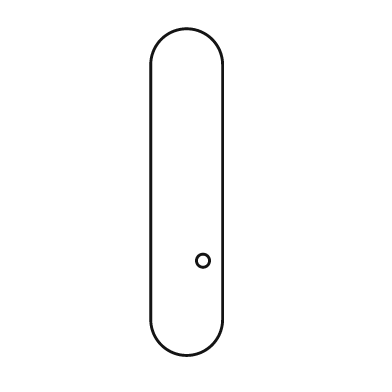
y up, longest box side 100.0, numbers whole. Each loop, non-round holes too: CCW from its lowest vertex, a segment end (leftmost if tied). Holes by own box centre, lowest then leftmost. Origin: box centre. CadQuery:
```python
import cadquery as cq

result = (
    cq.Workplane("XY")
    .moveTo(-11.0, -39.0)
    .threePointArc((0.0, -50.0), (11.0, -39.0))
    .lineTo(11.0, 39.0)
    .threePointArc((0.0, 50.0), (-11.0, 39.0))
    .close()
    .moveTo(5.0, -21.0)
    .circle(2.0)
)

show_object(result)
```